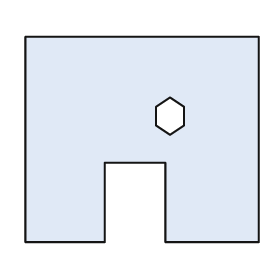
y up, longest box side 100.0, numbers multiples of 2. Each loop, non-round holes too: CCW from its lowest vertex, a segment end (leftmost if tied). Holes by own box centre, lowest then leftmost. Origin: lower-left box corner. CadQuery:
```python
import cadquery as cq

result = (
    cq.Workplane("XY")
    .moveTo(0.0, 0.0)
    .lineTo(34.0, 0.0)
    .lineTo(34.0, 34.0)
    .lineTo(60.0, 34.0)
    .lineTo(60.0, 0.0)
    .lineTo(100.0, 0.0)
    .lineTo(100.0, 88.0)
    .lineTo(0.0, 88.0)
    .close()
    .moveTo(62.0, 46.0)
    .lineTo(68.0, 50.0)
    .lineTo(68.0, 58.0)
    .lineTo(62.0, 62.0)
    .lineTo(56.0, 58.0)
    .lineTo(56.0, 50.0)
    .close()
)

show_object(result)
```